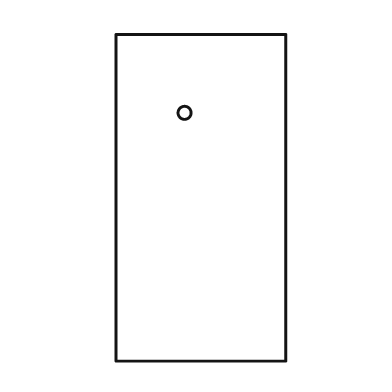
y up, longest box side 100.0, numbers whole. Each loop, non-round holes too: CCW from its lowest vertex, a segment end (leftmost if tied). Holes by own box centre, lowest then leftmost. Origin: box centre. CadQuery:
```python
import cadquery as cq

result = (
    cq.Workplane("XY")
    .moveTo(-26.0, -50.0)
    .lineTo(26.0, -50.0)
    .lineTo(26.0, 50.0)
    .lineTo(-26.0, 50.0)
    .close()
    .moveTo(-5.0, 26.0)
    .circle(2.0)
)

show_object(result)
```